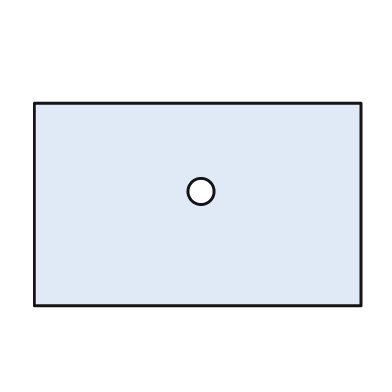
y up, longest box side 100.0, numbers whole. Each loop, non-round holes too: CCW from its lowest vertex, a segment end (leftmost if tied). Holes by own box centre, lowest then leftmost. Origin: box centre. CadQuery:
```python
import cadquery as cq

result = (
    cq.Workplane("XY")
    .moveTo(-50.0, -31.0)
    .lineTo(50.0, -31.0)
    .lineTo(50.0, 31.0)
    .lineTo(-50.0, 31.0)
    .close()
    .moveTo(1.0, 4.0)
    .circle(4.0)
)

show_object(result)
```